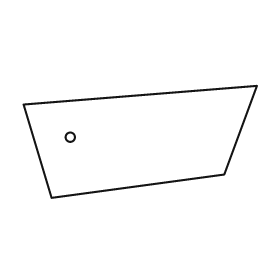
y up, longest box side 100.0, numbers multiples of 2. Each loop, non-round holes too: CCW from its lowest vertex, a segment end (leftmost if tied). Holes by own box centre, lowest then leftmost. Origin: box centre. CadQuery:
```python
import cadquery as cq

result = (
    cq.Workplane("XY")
    .moveTo(-38.0, -24.0)
    .lineTo(36.0, -14.0)
    .lineTo(50.0, 24.0)
    .lineTo(-50.0, 16.0)
    .close()
    .moveTo(-30.0, 2.0)
    .circle(2.0)
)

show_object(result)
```